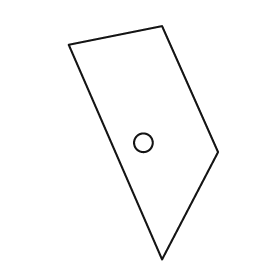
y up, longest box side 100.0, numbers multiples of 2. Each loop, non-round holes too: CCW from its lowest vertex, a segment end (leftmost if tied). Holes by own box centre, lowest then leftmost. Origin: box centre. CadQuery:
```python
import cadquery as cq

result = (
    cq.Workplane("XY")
    .moveTo(8.0, -50.0)
    .lineTo(32.0, -4.0)
    .lineTo(8.0, 50.0)
    .lineTo(-32.0, 42.0)
    .close()
    .moveTo(0.0, 0.0)
    .circle(4.0)
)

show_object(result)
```